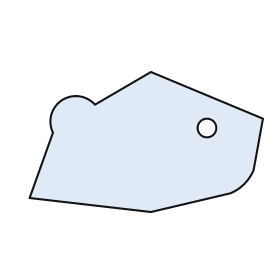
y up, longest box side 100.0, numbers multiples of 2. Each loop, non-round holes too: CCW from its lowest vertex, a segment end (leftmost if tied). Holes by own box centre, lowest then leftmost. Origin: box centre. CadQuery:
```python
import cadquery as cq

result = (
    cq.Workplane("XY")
    .moveTo(2.0, -30.0)
    .lineTo(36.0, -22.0)
    .threePointArc((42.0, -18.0), (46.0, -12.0))
    .lineTo(50.0, 10.0)
    .lineTo(2.0, 30.0)
    .lineTo(-22.0, 16.0)
    .threePointArc((-36.0, 18.0), (-40.0, 4.0))
    .lineTo(-50.0, -24.0)
    .close()
    .moveTo(26.0, 6.0)
    .circle(4.0)
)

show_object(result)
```